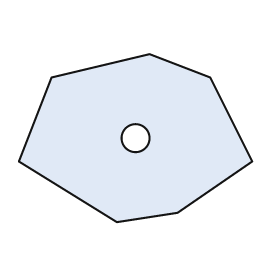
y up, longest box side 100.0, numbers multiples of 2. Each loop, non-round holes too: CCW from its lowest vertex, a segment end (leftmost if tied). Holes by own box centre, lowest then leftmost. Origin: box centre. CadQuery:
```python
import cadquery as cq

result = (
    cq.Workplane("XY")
    .moveTo(-8.0, -36.0)
    .lineTo(18.0, -32.0)
    .lineTo(50.0, -10.0)
    .lineTo(32.0, 26.0)
    .lineTo(6.0, 36.0)
    .lineTo(-36.0, 26.0)
    .lineTo(-50.0, -10.0)
    .close()
    .moveTo(0.0, 0.0)
    .circle(6.0)
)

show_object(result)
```